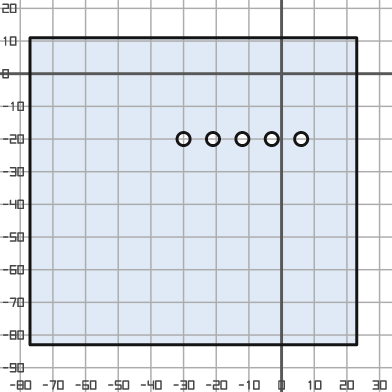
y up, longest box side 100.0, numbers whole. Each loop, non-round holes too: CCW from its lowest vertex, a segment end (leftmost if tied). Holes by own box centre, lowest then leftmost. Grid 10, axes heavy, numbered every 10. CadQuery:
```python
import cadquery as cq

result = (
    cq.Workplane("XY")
    .moveTo(-77.0, -83.0)
    .lineTo(23.0, -83.0)
    .lineTo(23.0, 11.0)
    .lineTo(-77.0, 11.0)
    .close()
    .moveTo(-30.0, -20.0)
    .circle(2.0)
    .moveTo(-21.0, -20.0)
    .circle(2.0)
    .moveTo(-12.0, -20.0)
    .circle(2.0)
    .moveTo(-3.0, -20.0)
    .circle(2.0)
    .moveTo(6.0, -20.0)
    .circle(2.0)
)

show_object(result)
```